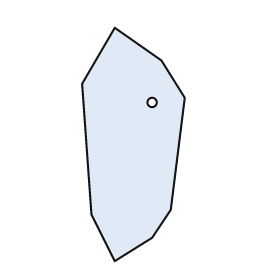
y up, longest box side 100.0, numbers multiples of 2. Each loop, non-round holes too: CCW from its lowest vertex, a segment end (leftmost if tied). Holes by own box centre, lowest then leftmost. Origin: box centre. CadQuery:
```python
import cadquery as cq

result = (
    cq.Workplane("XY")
    .moveTo(-8.0, -50.0)
    .lineTo(8.0, -40.0)
    .lineTo(16.0, -28.0)
    .lineTo(22.0, 20.0)
    .lineTo(12.0, 36.0)
    .lineTo(-8.0, 50.0)
    .lineTo(-22.0, 26.0)
    .lineTo(-18.0, -30.0)
    .close()
    .moveTo(8.0, 18.0)
    .circle(2.0)
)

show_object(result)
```